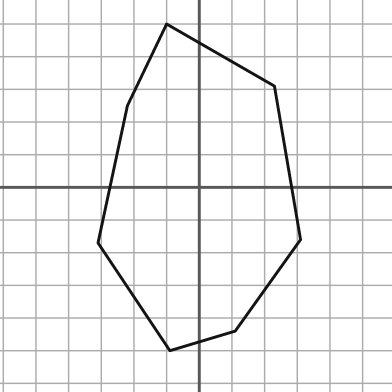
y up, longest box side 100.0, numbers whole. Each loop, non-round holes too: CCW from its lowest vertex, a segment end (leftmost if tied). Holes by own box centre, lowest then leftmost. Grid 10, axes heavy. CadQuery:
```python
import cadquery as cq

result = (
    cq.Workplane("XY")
    .moveTo(-9.0, -50.0)
    .lineTo(11.0, -44.0)
    .lineTo(31.0, -16.0)
    .lineTo(23.0, 31.0)
    .lineTo(-10.0, 50.0)
    .lineTo(-22.0, 25.0)
    .lineTo(-31.0, -17.0)
    .close()
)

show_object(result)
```